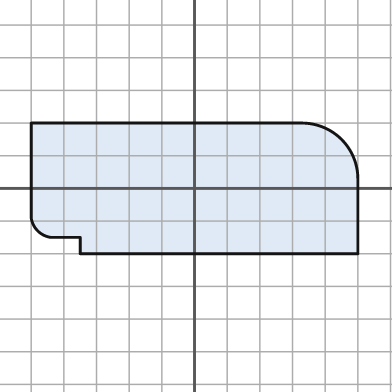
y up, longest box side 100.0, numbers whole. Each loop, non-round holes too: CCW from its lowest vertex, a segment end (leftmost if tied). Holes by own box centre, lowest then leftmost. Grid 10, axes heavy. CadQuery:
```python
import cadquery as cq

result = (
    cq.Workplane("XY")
    .moveTo(-35.0, -20.0)
    .lineTo(50.0, -20.0)
    .lineTo(50.0, 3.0)
    .threePointArc((45.0, 15.0), (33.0, 20.0))
    .lineTo(-50.0, 20.0)
    .lineTo(-50.0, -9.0)
    .threePointArc((-48.0, -13.0), (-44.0, -15.0))
    .lineTo(-35.0, -15.0)
    .close()
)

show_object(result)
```